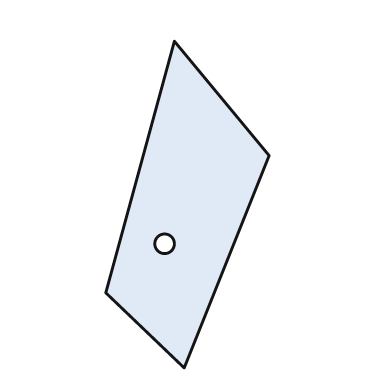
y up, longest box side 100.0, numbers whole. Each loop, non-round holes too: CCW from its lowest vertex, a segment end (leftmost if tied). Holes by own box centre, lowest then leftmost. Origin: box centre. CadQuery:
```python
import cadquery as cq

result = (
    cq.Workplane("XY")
    .moveTo(-1.0, -50.0)
    .lineTo(25.0, 15.0)
    .lineTo(-4.0, 50.0)
    .lineTo(-25.0, -27.0)
    .close()
    .moveTo(-7.0, -12.0)
    .circle(3.0)
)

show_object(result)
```